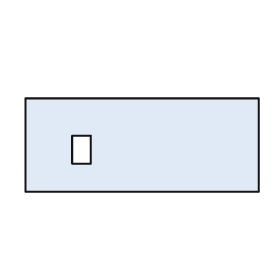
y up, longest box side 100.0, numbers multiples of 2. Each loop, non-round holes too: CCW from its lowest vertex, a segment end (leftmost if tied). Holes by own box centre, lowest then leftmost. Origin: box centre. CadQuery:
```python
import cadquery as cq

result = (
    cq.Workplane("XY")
    .moveTo(-50.0, -20.0)
    .lineTo(50.0, -20.0)
    .lineTo(50.0, 20.0)
    .lineTo(-50.0, 20.0)
    .close()
    .moveTo(-30.0, -8.0)
    .lineTo(-22.0, -8.0)
    .lineTo(-22.0, 4.0)
    .lineTo(-30.0, 4.0)
    .close()
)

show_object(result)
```